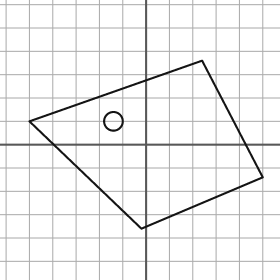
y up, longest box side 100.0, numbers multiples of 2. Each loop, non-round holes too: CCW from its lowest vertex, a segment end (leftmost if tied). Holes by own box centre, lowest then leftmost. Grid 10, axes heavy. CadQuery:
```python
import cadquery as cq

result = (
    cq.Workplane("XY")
    .moveTo(-2.0, -36.0)
    .lineTo(50.0, -14.0)
    .lineTo(24.0, 36.0)
    .lineTo(-50.0, 10.0)
    .close()
    .moveTo(-14.0, 10.0)
    .circle(4.0)
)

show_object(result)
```